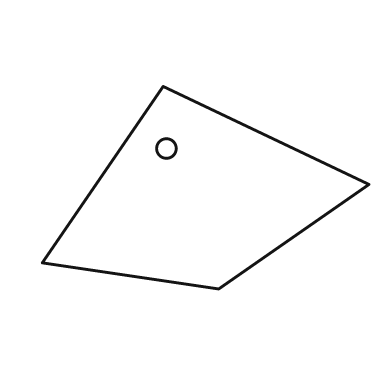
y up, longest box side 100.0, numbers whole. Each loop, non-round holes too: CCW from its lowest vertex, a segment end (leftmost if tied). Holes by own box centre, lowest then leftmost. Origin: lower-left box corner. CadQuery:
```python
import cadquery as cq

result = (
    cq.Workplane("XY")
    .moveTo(54.0, 0.0)
    .lineTo(100.0, 32.0)
    .lineTo(37.0, 62.0)
    .lineTo(0.0, 8.0)
    .close()
    .moveTo(38.0, 43.0)
    .circle(3.0)
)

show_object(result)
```